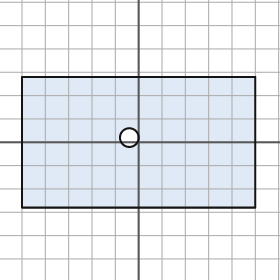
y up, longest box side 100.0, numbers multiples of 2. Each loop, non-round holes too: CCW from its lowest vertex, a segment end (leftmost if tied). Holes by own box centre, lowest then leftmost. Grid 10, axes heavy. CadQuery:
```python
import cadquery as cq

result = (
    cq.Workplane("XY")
    .moveTo(-50.0, -28.0)
    .lineTo(50.0, -28.0)
    .lineTo(50.0, 28.0)
    .lineTo(-50.0, 28.0)
    .close()
    .moveTo(-4.0, 2.0)
    .circle(4.0)
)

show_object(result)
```